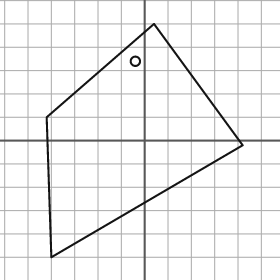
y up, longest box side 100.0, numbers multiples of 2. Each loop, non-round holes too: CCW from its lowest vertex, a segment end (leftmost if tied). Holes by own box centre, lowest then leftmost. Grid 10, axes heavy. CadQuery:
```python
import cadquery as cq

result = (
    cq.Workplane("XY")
    .moveTo(-40.0, -50.0)
    .lineTo(42.0, -2.0)
    .lineTo(4.0, 50.0)
    .lineTo(-42.0, 10.0)
    .close()
    .moveTo(-4.0, 34.0)
    .circle(2.0)
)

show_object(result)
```